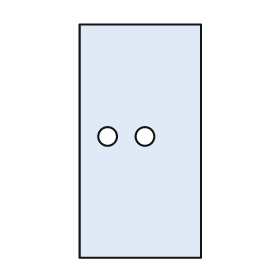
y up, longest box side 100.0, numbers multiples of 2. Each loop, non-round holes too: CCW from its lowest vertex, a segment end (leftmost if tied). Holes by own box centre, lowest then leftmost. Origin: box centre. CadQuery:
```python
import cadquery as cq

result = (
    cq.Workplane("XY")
    .moveTo(-26.0, -50.0)
    .lineTo(26.0, -50.0)
    .lineTo(26.0, 50.0)
    .lineTo(-26.0, 50.0)
    .close()
    .moveTo(-14.0, 2.0)
    .circle(4.0)
    .moveTo(2.0, 2.0)
    .circle(4.0)
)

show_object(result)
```